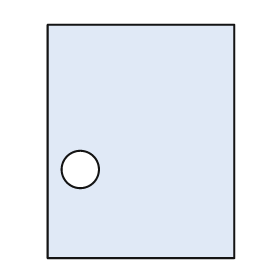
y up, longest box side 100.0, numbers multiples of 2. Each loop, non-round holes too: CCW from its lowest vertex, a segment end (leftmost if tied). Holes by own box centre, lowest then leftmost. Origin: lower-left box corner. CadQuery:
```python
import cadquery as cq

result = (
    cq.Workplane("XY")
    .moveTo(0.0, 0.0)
    .lineTo(80.0, 0.0)
    .lineTo(80.0, 100.0)
    .lineTo(0.0, 100.0)
    .close()
    .moveTo(14.0, 38.0)
    .circle(8.0)
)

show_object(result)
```